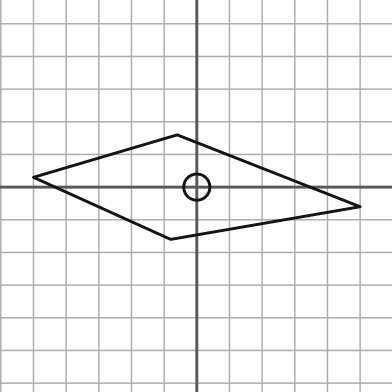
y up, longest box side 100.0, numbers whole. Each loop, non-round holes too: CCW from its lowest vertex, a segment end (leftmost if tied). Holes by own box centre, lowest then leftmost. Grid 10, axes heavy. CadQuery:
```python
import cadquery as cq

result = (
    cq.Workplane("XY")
    .moveTo(-8.0, -16.0)
    .lineTo(50.0, -6.0)
    .lineTo(-6.0, 16.0)
    .lineTo(-50.0, 3.0)
    .close()
    .moveTo(0.0, 0.0)
    .circle(4.0)
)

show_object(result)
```